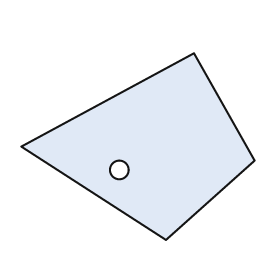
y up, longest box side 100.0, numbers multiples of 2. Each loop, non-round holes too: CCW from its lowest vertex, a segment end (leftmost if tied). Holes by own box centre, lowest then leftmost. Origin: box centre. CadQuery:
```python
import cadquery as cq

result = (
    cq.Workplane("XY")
    .moveTo(12.0, -40.0)
    .lineTo(50.0, -6.0)
    .lineTo(24.0, 40.0)
    .lineTo(-50.0, 0.0)
    .close()
    .moveTo(-8.0, -10.0)
    .circle(4.0)
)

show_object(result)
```